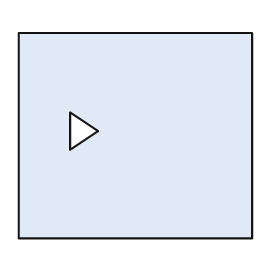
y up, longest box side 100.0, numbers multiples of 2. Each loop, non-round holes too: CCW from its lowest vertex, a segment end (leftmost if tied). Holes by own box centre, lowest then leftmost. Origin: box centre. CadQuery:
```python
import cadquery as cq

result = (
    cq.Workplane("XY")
    .moveTo(-50.0, -44.0)
    .lineTo(50.0, -44.0)
    .lineTo(50.0, 44.0)
    .lineTo(-50.0, 44.0)
    .close()
    .moveTo(-28.0, -6.0)
    .lineTo(-16.0, 2.0)
    .lineTo(-28.0, 10.0)
    .close()
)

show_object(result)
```